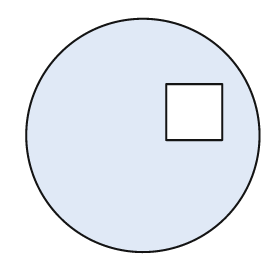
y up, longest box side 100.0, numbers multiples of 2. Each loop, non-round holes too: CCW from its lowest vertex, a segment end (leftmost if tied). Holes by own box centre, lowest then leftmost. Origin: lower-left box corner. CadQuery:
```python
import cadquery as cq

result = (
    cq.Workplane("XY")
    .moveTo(50.0, 50.0)
    .circle(50.0)
    .moveTo(60.0, 48.0)
    .lineTo(84.0, 48.0)
    .lineTo(84.0, 72.0)
    .lineTo(60.0, 72.0)
    .close()
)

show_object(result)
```